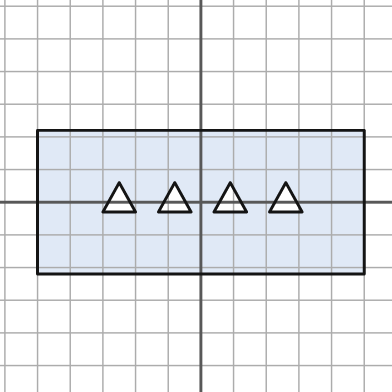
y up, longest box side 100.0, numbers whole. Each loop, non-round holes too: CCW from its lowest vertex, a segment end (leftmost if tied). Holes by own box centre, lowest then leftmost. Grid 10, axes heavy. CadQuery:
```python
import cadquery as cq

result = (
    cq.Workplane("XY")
    .moveTo(-50.0, -22.0)
    .lineTo(50.0, -22.0)
    .lineTo(50.0, 22.0)
    .lineTo(-50.0, 22.0)
    .close()
    .moveTo(-30.0, -3.0)
    .lineTo(-20.0, -3.0)
    .lineTo(-25.0, 6.0)
    .close()
    .moveTo(-13.0, -3.0)
    .lineTo(-3.0, -3.0)
    .lineTo(-8.0, 6.0)
    .close()
    .moveTo(4.0, -3.0)
    .lineTo(14.0, -3.0)
    .lineTo(9.0, 6.0)
    .close()
    .moveTo(21.0, -3.0)
    .lineTo(31.0, -3.0)
    .lineTo(26.0, 6.0)
    .close()
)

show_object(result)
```